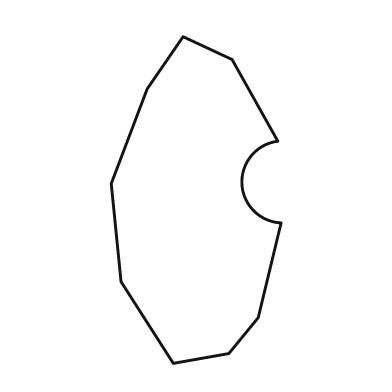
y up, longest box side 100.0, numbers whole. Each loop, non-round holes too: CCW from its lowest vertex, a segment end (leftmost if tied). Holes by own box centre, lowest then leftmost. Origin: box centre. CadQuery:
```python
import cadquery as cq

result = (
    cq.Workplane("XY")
    .moveTo(-7.0, -50.0)
    .lineTo(10.0, -47.0)
    .lineTo(19.0, -36.0)
    .lineTo(26.0, -7.0)
    .threePointArc((14.0, 5.0), (25.0, 18.0))
    .lineTo(11.0, 43.0)
    .lineTo(-4.0, 50.0)
    .lineTo(-15.0, 34.0)
    .lineTo(-26.0, 5.0)
    .lineTo(-23.0, -25.0)
    .close()
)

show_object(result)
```